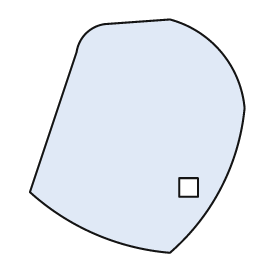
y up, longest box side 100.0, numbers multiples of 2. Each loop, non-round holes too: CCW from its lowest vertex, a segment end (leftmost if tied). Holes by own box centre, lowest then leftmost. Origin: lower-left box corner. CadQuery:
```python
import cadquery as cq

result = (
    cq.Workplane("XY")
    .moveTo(60.0, 0.0)
    .threePointArc((82.0, 28.0), (92.0, 62.0))
    .threePointArc((82.0, 86.0), (60.0, 100.0))
    .lineTo(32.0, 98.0)
    .threePointArc((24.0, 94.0), (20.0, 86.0))
    .lineTo(0.0, 26.0)
    .threePointArc((28.0, 8.0), (60.0, 0.0))
    .close()
    .moveTo(64.0, 24.0)
    .lineTo(72.0, 24.0)
    .lineTo(72.0, 32.0)
    .lineTo(64.0, 32.0)
    .close()
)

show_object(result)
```